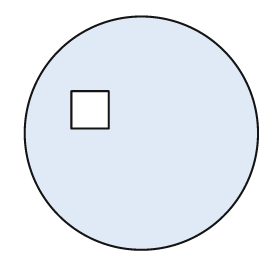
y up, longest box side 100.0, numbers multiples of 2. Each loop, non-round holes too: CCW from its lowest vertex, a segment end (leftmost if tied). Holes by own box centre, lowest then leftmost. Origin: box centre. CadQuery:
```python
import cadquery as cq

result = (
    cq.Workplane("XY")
    .moveTo(0.0, 0.0)
    .circle(50.0)
    .moveTo(-30.0, 2.0)
    .lineTo(-14.0, 2.0)
    .lineTo(-14.0, 18.0)
    .lineTo(-30.0, 18.0)
    .close()
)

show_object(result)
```